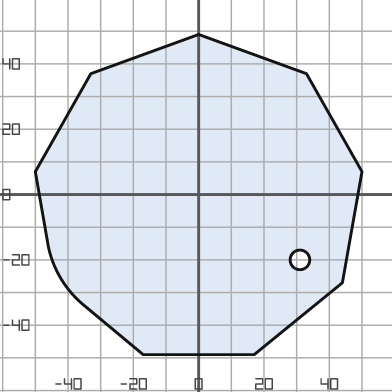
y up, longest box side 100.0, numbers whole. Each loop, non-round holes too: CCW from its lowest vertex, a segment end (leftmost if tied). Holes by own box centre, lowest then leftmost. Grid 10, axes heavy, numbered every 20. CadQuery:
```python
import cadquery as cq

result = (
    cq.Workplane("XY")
    .moveTo(-17.0, -49.0)
    .lineTo(17.0, -49.0)
    .lineTo(44.0, -27.0)
    .lineTo(50.0, 7.0)
    .lineTo(33.0, 37.0)
    .lineTo(0.0, 49.0)
    .lineTo(-33.0, 37.0)
    .lineTo(-50.0, 7.0)
    .lineTo(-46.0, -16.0)
    .threePointArc((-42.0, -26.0), (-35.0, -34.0))
    .close()
    .moveTo(31.0, -20.0)
    .circle(3.0)
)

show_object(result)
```